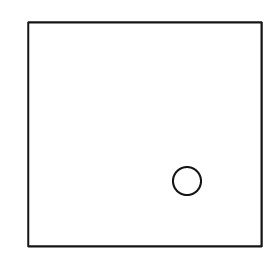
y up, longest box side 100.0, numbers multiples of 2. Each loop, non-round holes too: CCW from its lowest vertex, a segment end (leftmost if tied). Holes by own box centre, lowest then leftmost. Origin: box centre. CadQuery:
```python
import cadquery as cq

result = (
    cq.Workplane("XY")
    .moveTo(-50.0, -48.0)
    .lineTo(50.0, -48.0)
    .lineTo(50.0, 48.0)
    .lineTo(-50.0, 48.0)
    .close()
    .moveTo(18.0, -20.0)
    .circle(6.0)
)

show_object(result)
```